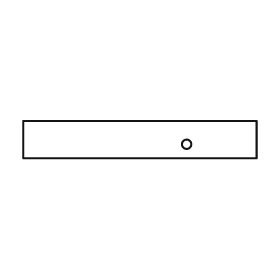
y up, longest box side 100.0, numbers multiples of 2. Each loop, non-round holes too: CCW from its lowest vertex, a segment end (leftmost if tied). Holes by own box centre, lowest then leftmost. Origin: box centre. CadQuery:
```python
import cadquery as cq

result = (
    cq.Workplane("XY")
    .moveTo(-50.0, -8.0)
    .lineTo(50.0, -8.0)
    .lineTo(50.0, 8.0)
    .lineTo(-50.0, 8.0)
    .close()
    .moveTo(20.0, -2.0)
    .circle(2.0)
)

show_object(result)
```